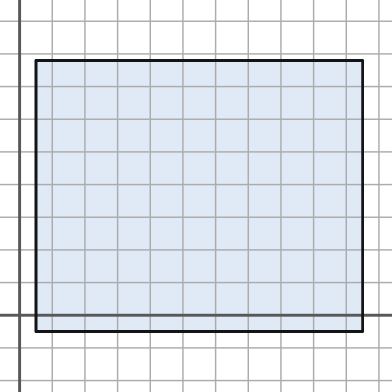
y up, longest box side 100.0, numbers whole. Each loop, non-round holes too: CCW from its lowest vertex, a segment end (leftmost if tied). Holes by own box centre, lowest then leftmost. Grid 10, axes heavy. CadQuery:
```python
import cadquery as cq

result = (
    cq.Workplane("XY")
    .moveTo(5.0, -5.0)
    .lineTo(105.0, -5.0)
    .lineTo(105.0, 78.0)
    .lineTo(5.0, 78.0)
    .close()
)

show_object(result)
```